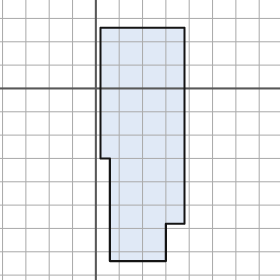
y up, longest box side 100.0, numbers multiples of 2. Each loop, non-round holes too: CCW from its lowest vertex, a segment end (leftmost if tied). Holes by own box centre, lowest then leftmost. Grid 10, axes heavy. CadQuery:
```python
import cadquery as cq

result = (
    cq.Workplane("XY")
    .moveTo(6.0, -74.0)
    .lineTo(30.0, -74.0)
    .lineTo(30.0, -58.0)
    .lineTo(38.0, -58.0)
    .lineTo(38.0, 26.0)
    .lineTo(2.0, 26.0)
    .lineTo(2.0, -30.0)
    .lineTo(6.0, -30.0)
    .close()
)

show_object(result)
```